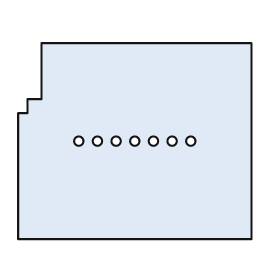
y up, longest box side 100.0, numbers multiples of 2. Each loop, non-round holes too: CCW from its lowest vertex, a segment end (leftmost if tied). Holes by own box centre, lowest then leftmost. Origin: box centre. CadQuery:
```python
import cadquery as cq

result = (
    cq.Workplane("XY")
    .moveTo(-50.0, -42.0)
    .lineTo(50.0, -42.0)
    .lineTo(50.0, 42.0)
    .lineTo(-40.0, 42.0)
    .lineTo(-40.0, 18.0)
    .lineTo(-46.0, 18.0)
    .lineTo(-46.0, 12.0)
    .lineTo(-50.0, 12.0)
    .close()
    .moveTo(-24.0, 0.0)
    .circle(2.0)
    .moveTo(-16.0, 0.0)
    .circle(2.0)
    .moveTo(-8.0, 0.0)
    .circle(2.0)
    .moveTo(0.0, 0.0)
    .circle(2.0)
    .moveTo(8.0, 0.0)
    .circle(2.0)
    .moveTo(16.0, 0.0)
    .circle(2.0)
    .moveTo(24.0, 0.0)
    .circle(2.0)
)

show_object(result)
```